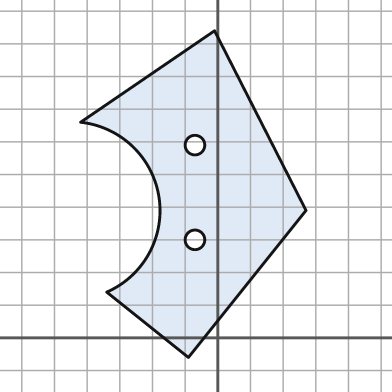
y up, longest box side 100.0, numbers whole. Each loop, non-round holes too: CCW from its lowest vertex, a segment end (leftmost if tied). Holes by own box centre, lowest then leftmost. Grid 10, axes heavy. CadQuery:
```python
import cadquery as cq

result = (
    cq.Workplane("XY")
    .moveTo(-9.0, -6.0)
    .lineTo(27.0, 39.0)
    .lineTo(-1.0, 94.0)
    .lineTo(-42.0, 66.0)
    .threePointArc((-18.0, 43.0), (-34.0, 14.0))
    .close()
    .moveTo(-7.0, 30.0)
    .circle(3.0)
    .moveTo(-7.0, 59.0)
    .circle(3.0)
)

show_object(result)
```